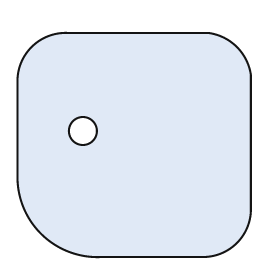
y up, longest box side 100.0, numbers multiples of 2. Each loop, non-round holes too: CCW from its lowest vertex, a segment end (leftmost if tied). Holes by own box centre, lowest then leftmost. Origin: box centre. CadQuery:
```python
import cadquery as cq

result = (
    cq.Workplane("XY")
    .moveTo(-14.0, -48.0)
    .lineTo(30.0, -48.0)
    .threePointArc((44.0, -42.0), (50.0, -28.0))
    .lineTo(50.0, 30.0)
    .threePointArc((44.0, 42.0), (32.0, 48.0))
    .lineTo(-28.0, 48.0)
    .threePointArc((-44.0, 42.0), (-50.0, 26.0))
    .lineTo(-50.0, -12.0)
    .threePointArc((-40.0, -38.0), (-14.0, -48.0))
    .close()
    .moveTo(-22.0, 6.0)
    .circle(6.0)
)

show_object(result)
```